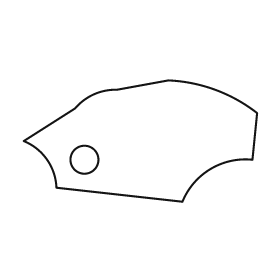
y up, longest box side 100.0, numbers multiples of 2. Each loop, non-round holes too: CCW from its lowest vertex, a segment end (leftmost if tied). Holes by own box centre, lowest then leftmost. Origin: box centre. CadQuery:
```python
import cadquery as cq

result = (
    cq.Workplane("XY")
    .moveTo(18.0, -26.0)
    .threePointArc((30.0, -12.0), (48.0, -8.0))
    .lineTo(50.0, 12.0)
    .threePointArc((32.0, 22.0), (12.0, 26.0))
    .lineTo(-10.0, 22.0)
    .threePointArc((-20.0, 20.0), (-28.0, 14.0))
    .lineTo(-50.0, 0.0)
    .threePointArc((-40.0, -8.0), (-36.0, -20.0))
    .close()
    .moveTo(-24.0, -8.0)
    .circle(6.0)
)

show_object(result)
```